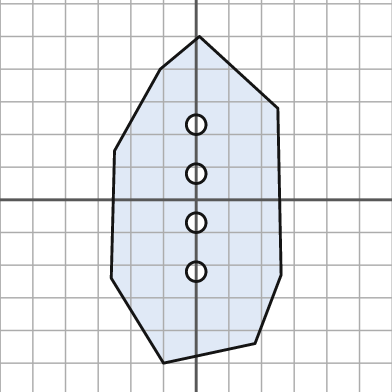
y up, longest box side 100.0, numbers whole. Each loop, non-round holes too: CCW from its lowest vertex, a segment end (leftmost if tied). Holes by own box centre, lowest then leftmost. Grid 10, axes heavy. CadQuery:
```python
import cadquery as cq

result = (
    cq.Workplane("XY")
    .moveTo(-10.0, -50.0)
    .lineTo(18.0, -44.0)
    .lineTo(26.0, -23.0)
    .lineTo(25.0, 28.0)
    .lineTo(1.0, 50.0)
    .lineTo(-11.0, 40.0)
    .lineTo(-25.0, 15.0)
    .lineTo(-26.0, -24.0)
    .close()
    .moveTo(0.0, -22.0)
    .circle(3.0)
    .moveTo(0.0, -7.0)
    .circle(3.0)
    .moveTo(0.0, 8.0)
    .circle(3.0)
    .moveTo(0.0, 23.0)
    .circle(3.0)
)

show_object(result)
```